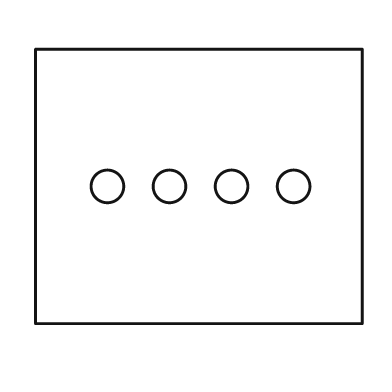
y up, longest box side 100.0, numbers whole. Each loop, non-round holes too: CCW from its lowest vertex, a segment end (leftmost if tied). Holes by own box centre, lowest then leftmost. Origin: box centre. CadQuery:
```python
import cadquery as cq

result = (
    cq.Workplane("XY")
    .moveTo(-50.0, -42.0)
    .lineTo(50.0, -42.0)
    .lineTo(50.0, 42.0)
    .lineTo(-50.0, 42.0)
    .close()
    .moveTo(-28.0, 0.0)
    .circle(5.0)
    .moveTo(-9.0, 0.0)
    .circle(5.0)
    .moveTo(10.0, 0.0)
    .circle(5.0)
    .moveTo(29.0, 0.0)
    .circle(5.0)
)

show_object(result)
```